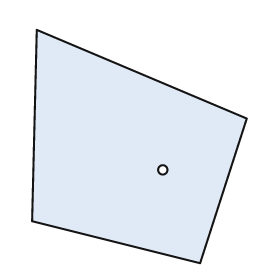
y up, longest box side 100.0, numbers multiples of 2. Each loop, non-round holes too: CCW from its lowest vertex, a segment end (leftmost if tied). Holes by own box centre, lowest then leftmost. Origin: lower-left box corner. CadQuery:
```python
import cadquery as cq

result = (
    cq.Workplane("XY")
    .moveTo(72.0, 0.0)
    .lineTo(92.0, 62.0)
    .lineTo(2.0, 100.0)
    .lineTo(0.0, 18.0)
    .close()
    .moveTo(56.0, 40.0)
    .circle(2.0)
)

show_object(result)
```